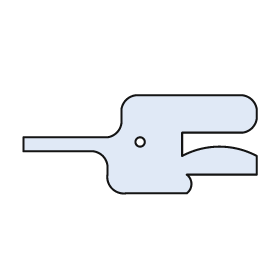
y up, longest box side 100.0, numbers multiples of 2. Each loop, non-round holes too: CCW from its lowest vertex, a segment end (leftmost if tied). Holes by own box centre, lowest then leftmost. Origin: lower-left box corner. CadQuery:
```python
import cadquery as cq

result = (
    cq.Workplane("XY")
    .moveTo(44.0, 0.0)
    .lineTo(70.0, 0.0)
    .threePointArc((72.0, 4.0), (70.0, 8.0))
    .lineTo(100.0, 8.0)
    .lineTo(100.0, 16.0)
    .threePointArc((84.0, 20.0), (68.0, 16.0))
    .lineTo(68.0, 26.0)
    .lineTo(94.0, 26.0)
    .threePointArc((98.0, 28.0), (100.0, 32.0))
    .lineTo(100.0, 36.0)
    .threePointArc((98.0, 40.0), (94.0, 42.0))
    .lineTo(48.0, 42.0)
    .threePointArc((44.0, 40.0), (42.0, 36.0))
    .lineTo(42.0, 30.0)
    .threePointArc((40.0, 26.0), (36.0, 24.0))
    .lineTo(0.0, 24.0)
    .lineTo(0.0, 18.0)
    .lineTo(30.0, 18.0)
    .threePointArc((34.0, 16.0), (36.0, 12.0))
    .lineTo(36.0, 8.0)
    .threePointArc((38.0, 2.0), (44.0, 0.0))
    .close()
    .moveTo(50.0, 22.0)
    .circle(2.0)
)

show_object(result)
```